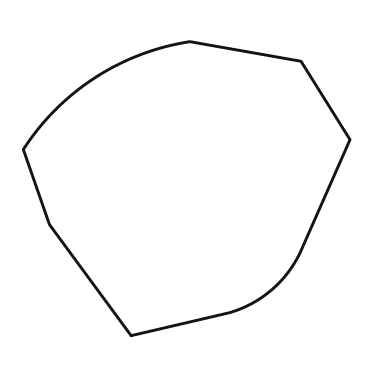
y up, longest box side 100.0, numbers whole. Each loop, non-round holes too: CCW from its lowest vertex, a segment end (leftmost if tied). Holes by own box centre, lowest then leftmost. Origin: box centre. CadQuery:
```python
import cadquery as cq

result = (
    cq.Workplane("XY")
    .moveTo(-17.0, -45.0)
    .lineTo(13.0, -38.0)
    .threePointArc((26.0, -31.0), (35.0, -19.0))
    .lineTo(50.0, 15.0)
    .lineTo(35.0, 39.0)
    .lineTo(1.0, 45.0)
    .threePointArc((-28.0, 34.0), (-50.0, 12.0))
    .lineTo(-42.0, -11.0)
    .close()
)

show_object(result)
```